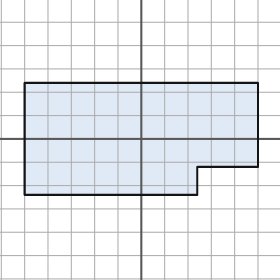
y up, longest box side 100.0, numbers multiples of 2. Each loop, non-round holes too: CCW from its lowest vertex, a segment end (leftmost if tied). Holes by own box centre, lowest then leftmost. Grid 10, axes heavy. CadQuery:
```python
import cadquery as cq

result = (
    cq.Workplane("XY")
    .moveTo(-50.0, -24.0)
    .lineTo(24.0, -24.0)
    .lineTo(24.0, -12.0)
    .lineTo(50.0, -12.0)
    .lineTo(50.0, 24.0)
    .lineTo(-50.0, 24.0)
    .close()
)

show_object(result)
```